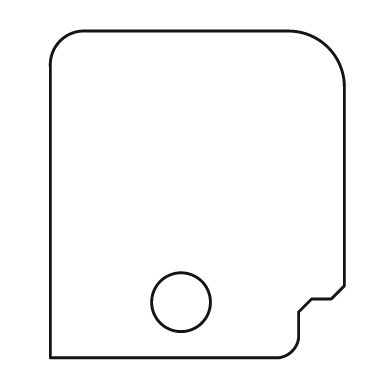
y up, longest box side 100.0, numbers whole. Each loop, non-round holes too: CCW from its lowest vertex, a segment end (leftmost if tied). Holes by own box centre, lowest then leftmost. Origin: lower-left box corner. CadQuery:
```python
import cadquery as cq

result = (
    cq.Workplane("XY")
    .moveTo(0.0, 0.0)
    .lineTo(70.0, 0.0)
    .threePointArc((74.0, 2.0), (76.0, 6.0))
    .lineTo(76.0, 14.0)
    .lineTo(80.0, 18.0)
    .lineTo(86.0, 18.0)
    .lineTo(90.0, 22.0)
    .lineTo(90.0, 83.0)
    .threePointArc((85.0, 95.0), (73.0, 100.0))
    .lineTo(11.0, 100.0)
    .threePointArc((3.0, 97.0), (0.0, 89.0))
    .close()
    .moveTo(40.0, 17.0)
    .circle(9.0)
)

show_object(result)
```